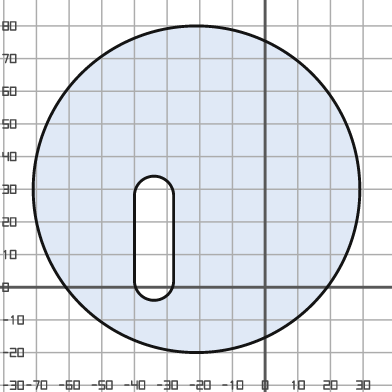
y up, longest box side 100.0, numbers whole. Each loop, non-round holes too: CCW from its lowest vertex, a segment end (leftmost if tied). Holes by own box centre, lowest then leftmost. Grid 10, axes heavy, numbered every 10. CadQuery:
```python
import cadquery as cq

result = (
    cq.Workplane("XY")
    .moveTo(-21.0, 30.0)
    .circle(50.0)
    .moveTo(-40.0, 2.0)
    .threePointArc((-34.0, -4.0), (-28.0, 2.0))
    .lineTo(-28.0, 28.0)
    .threePointArc((-34.0, 34.0), (-40.0, 28.0))
    .close()
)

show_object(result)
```